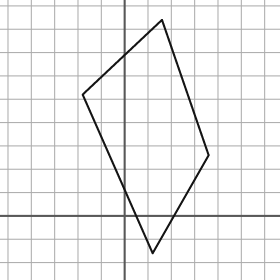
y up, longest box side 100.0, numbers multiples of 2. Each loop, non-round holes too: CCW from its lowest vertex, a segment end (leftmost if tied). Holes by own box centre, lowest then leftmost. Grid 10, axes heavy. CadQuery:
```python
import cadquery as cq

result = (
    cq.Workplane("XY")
    .moveTo(12.0, -16.0)
    .lineTo(36.0, 26.0)
    .lineTo(16.0, 84.0)
    .lineTo(-18.0, 52.0)
    .close()
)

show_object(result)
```